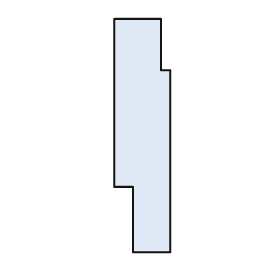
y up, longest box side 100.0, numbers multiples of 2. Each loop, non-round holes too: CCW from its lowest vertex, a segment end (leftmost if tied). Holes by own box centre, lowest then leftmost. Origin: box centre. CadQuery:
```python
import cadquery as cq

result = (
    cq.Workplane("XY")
    .moveTo(-4.0, -50.0)
    .lineTo(12.0, -50.0)
    .lineTo(12.0, 28.0)
    .lineTo(8.0, 28.0)
    .lineTo(8.0, 50.0)
    .lineTo(-12.0, 50.0)
    .lineTo(-12.0, -22.0)
    .lineTo(-4.0, -22.0)
    .close()
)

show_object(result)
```